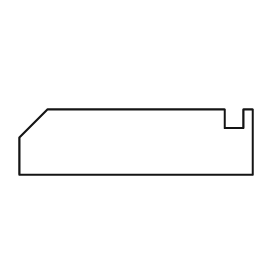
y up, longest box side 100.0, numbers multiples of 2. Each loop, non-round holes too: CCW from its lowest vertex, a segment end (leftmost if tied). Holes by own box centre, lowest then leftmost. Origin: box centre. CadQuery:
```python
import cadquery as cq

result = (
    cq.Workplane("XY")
    .moveTo(-50.0, -14.0)
    .lineTo(50.0, -14.0)
    .lineTo(50.0, 14.0)
    .lineTo(46.0, 14.0)
    .lineTo(46.0, 6.0)
    .lineTo(38.0, 6.0)
    .lineTo(38.0, 14.0)
    .lineTo(-38.0, 14.0)
    .lineTo(-50.0, 2.0)
    .close()
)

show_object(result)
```